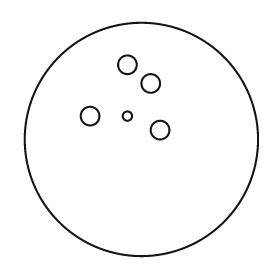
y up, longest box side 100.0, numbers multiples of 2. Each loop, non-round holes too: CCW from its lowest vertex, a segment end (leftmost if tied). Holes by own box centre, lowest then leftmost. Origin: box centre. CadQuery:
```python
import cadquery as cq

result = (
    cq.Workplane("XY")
    .moveTo(0.0, 0.0)
    .circle(50.0)
    .moveTo(8.0, 4.0)
    .circle(4.0)
    .moveTo(-22.0, 10.0)
    .circle(4.0)
    .moveTo(-6.0, 10.0)
    .circle(2.0)
    .moveTo(4.0, 24.0)
    .circle(4.0)
    .moveTo(-6.0, 32.0)
    .circle(4.0)
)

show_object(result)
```